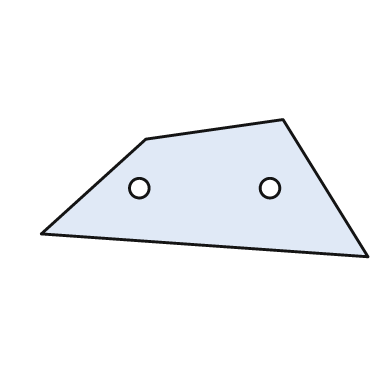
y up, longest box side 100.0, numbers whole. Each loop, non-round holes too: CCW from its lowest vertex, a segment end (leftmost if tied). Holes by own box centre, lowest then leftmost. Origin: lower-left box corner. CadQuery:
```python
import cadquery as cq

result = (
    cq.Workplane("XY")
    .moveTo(100.0, 0.0)
    .lineTo(74.0, 42.0)
    .lineTo(32.0, 36.0)
    .lineTo(0.0, 7.0)
    .close()
    .moveTo(30.0, 21.0)
    .circle(3.0)
    .moveTo(70.0, 21.0)
    .circle(3.0)
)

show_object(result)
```